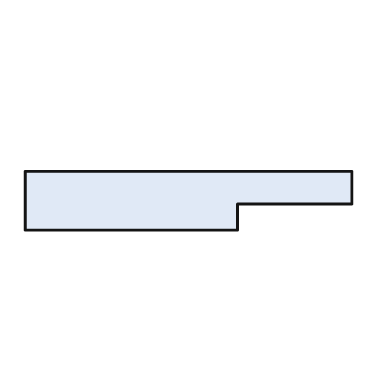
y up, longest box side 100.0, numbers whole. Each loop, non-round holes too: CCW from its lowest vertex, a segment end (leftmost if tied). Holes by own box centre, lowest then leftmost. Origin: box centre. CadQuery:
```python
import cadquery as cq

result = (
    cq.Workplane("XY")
    .moveTo(-50.0, -9.0)
    .lineTo(15.0, -9.0)
    .lineTo(15.0, -1.0)
    .lineTo(50.0, -1.0)
    .lineTo(50.0, 9.0)
    .lineTo(-50.0, 9.0)
    .close()
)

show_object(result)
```